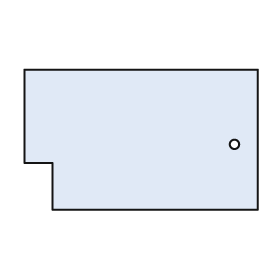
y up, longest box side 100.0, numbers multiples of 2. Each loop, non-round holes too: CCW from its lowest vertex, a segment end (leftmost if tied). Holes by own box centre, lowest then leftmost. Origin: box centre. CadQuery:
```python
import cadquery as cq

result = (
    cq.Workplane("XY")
    .moveTo(-38.0, -30.0)
    .lineTo(50.0, -30.0)
    .lineTo(50.0, 30.0)
    .lineTo(-50.0, 30.0)
    .lineTo(-50.0, -10.0)
    .lineTo(-38.0, -10.0)
    .close()
    .moveTo(40.0, -2.0)
    .circle(2.0)
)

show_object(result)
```